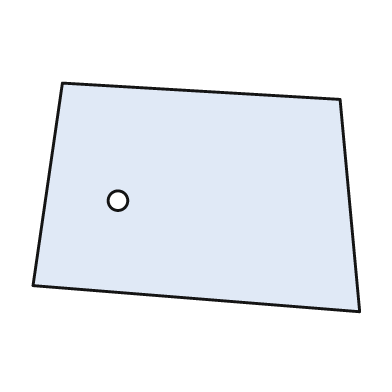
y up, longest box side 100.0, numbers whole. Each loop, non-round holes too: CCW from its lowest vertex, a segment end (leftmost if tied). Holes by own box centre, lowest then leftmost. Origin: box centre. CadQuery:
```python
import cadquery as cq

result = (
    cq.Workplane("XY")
    .moveTo(50.0, -35.0)
    .lineTo(44.0, 30.0)
    .lineTo(-41.0, 35.0)
    .lineTo(-50.0, -27.0)
    .close()
    .moveTo(-24.0, -1.0)
    .circle(3.0)
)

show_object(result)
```